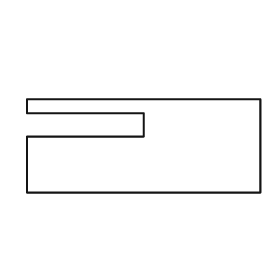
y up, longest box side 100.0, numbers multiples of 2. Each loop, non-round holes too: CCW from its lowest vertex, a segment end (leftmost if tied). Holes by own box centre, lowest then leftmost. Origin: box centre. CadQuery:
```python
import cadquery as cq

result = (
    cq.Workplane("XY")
    .moveTo(-50.0, -20.0)
    .lineTo(50.0, -20.0)
    .lineTo(50.0, 20.0)
    .lineTo(-50.0, 20.0)
    .lineTo(-50.0, 14.0)
    .lineTo(0.0, 14.0)
    .lineTo(0.0, 4.0)
    .lineTo(-50.0, 4.0)
    .close()
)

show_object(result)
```